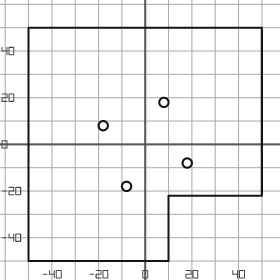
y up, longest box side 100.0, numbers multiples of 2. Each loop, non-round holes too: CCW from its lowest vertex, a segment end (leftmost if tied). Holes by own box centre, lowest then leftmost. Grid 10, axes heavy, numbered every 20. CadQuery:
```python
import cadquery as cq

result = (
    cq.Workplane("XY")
    .moveTo(-50.0, -50.0)
    .lineTo(10.0, -50.0)
    .lineTo(10.0, -22.0)
    .lineTo(50.0, -22.0)
    .lineTo(50.0, 50.0)
    .lineTo(-50.0, 50.0)
    .close()
    .moveTo(-8.0, -18.0)
    .circle(2.0)
    .moveTo(18.0, -8.0)
    .circle(2.0)
    .moveTo(-18.0, 8.0)
    .circle(2.0)
    .moveTo(8.0, 18.0)
    .circle(2.0)
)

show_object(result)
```